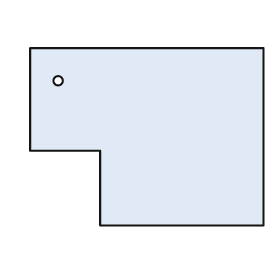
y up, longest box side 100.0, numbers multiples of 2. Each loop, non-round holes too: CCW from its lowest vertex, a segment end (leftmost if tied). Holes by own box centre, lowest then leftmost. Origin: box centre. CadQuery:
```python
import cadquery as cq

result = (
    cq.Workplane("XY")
    .moveTo(-20.0, -38.0)
    .lineTo(50.0, -38.0)
    .lineTo(50.0, 38.0)
    .lineTo(-50.0, 38.0)
    .lineTo(-50.0, -6.0)
    .lineTo(-20.0, -6.0)
    .close()
    .moveTo(-38.0, 24.0)
    .circle(2.0)
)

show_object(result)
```